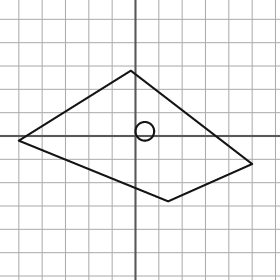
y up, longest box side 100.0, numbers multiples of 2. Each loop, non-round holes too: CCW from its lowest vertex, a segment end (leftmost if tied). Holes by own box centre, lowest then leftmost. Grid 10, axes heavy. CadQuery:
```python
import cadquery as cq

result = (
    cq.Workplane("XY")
    .moveTo(14.0, -28.0)
    .lineTo(50.0, -12.0)
    .lineTo(-2.0, 28.0)
    .lineTo(-50.0, -2.0)
    .close()
    .moveTo(4.0, 2.0)
    .circle(4.0)
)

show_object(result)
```